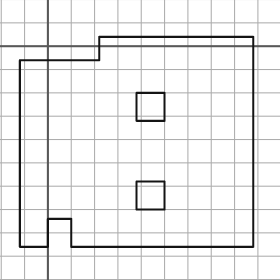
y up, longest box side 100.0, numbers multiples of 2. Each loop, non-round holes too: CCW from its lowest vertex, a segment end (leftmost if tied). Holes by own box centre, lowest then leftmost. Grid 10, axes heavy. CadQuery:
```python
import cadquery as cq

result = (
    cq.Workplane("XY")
    .moveTo(-12.0, -86.0)
    .lineTo(0.0, -86.0)
    .lineTo(0.0, -74.0)
    .lineTo(10.0, -74.0)
    .lineTo(10.0, -86.0)
    .lineTo(88.0, -86.0)
    .lineTo(88.0, 4.0)
    .lineTo(22.0, 4.0)
    .lineTo(22.0, -6.0)
    .lineTo(-12.0, -6.0)
    .close()
    .moveTo(38.0, -70.0)
    .lineTo(50.0, -70.0)
    .lineTo(50.0, -58.0)
    .lineTo(38.0, -58.0)
    .close()
    .moveTo(38.0, -32.0)
    .lineTo(50.0, -32.0)
    .lineTo(50.0, -20.0)
    .lineTo(38.0, -20.0)
    .close()
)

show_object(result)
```